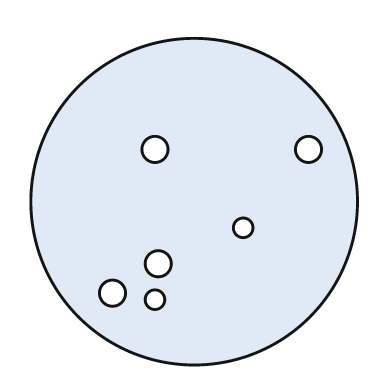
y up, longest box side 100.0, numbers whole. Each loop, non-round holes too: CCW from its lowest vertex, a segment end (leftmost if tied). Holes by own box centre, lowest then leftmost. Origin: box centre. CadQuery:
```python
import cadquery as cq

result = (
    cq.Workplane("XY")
    .moveTo(0.0, 0.0)
    .circle(50.0)
    .moveTo(-12.0, -30.0)
    .circle(3.0)
    .moveTo(-25.0, -28.0)
    .circle(4.0)
    .moveTo(-11.0, -19.0)
    .circle(4.0)
    .moveTo(15.0, -8.0)
    .circle(3.0)
    .moveTo(-12.0, 16.0)
    .circle(4.0)
    .moveTo(35.0, 16.0)
    .circle(4.0)
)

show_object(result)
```